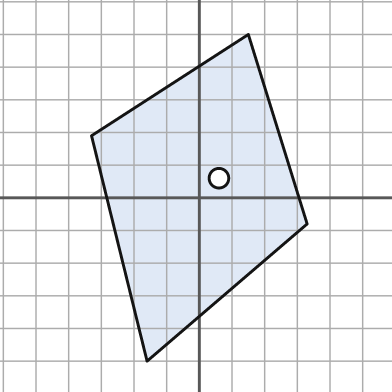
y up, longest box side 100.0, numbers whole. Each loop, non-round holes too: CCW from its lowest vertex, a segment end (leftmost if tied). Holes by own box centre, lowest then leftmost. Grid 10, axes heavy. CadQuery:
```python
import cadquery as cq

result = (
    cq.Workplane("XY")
    .moveTo(-16.0, -50.0)
    .lineTo(33.0, -8.0)
    .lineTo(15.0, 50.0)
    .lineTo(-33.0, 19.0)
    .close()
    .moveTo(6.0, 6.0)
    .circle(3.0)
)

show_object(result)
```